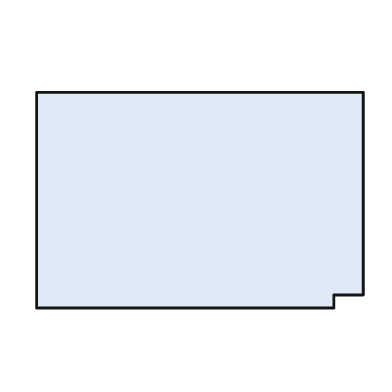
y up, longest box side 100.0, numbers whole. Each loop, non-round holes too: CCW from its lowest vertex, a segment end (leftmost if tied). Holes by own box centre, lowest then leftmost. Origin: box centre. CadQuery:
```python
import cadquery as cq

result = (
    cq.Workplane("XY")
    .moveTo(-50.0, -33.0)
    .lineTo(41.0, -33.0)
    .lineTo(41.0, -29.0)
    .lineTo(50.0, -29.0)
    .lineTo(50.0, 33.0)
    .lineTo(-50.0, 33.0)
    .close()
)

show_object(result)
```